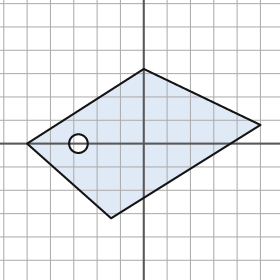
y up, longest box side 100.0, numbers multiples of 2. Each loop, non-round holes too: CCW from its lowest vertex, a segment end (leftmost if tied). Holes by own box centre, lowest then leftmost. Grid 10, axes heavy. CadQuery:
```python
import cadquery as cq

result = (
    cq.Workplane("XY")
    .moveTo(-14.0, -32.0)
    .lineTo(50.0, 8.0)
    .lineTo(0.0, 32.0)
    .lineTo(-50.0, 0.0)
    .close()
    .moveTo(-28.0, 0.0)
    .circle(4.0)
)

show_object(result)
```